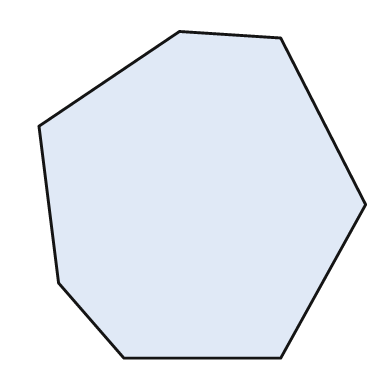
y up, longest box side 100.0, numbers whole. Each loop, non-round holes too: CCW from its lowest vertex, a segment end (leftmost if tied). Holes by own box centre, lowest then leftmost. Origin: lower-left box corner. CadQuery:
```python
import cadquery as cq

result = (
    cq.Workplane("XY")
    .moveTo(26.0, 0.0)
    .lineTo(74.0, 0.0)
    .lineTo(100.0, 47.0)
    .lineTo(74.0, 98.0)
    .lineTo(43.0, 100.0)
    .lineTo(0.0, 71.0)
    .lineTo(6.0, 23.0)
    .close()
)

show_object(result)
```